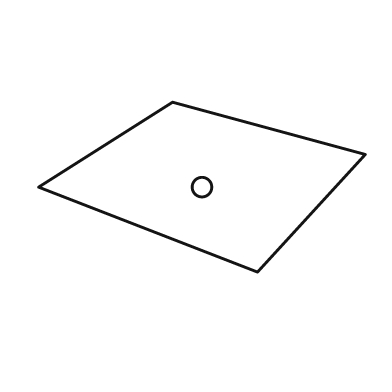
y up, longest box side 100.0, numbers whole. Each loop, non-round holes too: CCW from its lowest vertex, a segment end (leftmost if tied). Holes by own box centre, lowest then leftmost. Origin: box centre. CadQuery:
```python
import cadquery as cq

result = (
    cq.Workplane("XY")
    .moveTo(17.0, -26.0)
    .lineTo(50.0, 10.0)
    .lineTo(-9.0, 26.0)
    .lineTo(-50.0, 0.0)
    .close()
    .moveTo(0.0, 0.0)
    .circle(3.0)
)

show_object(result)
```